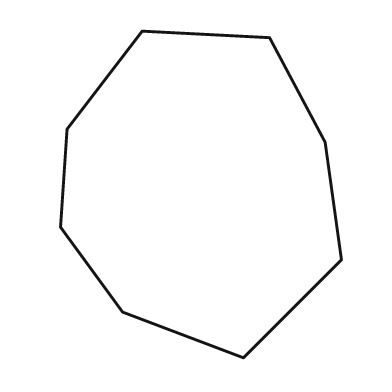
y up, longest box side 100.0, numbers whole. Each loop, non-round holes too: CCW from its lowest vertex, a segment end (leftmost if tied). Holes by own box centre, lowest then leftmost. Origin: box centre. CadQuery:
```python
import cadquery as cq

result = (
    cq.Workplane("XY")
    .moveTo(13.0, -50.0)
    .lineTo(43.0, -20.0)
    .lineTo(38.0, 16.0)
    .lineTo(21.0, 48.0)
    .lineTo(-18.0, 50.0)
    .lineTo(-41.0, 20.0)
    .lineTo(-43.0, -10.0)
    .lineTo(-24.0, -36.0)
    .close()
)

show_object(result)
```